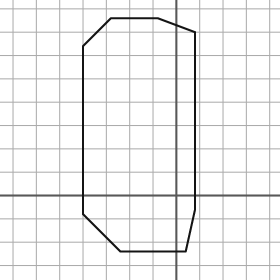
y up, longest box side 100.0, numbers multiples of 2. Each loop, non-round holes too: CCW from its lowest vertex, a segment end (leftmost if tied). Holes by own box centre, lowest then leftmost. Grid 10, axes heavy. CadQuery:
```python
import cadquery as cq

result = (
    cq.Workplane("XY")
    .moveTo(-24.0, -24.0)
    .lineTo(4.0, -24.0)
    .lineTo(8.0, -6.0)
    .lineTo(8.0, 70.0)
    .lineTo(-8.0, 76.0)
    .lineTo(-28.0, 76.0)
    .lineTo(-40.0, 64.0)
    .lineTo(-40.0, -8.0)
    .close()
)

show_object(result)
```